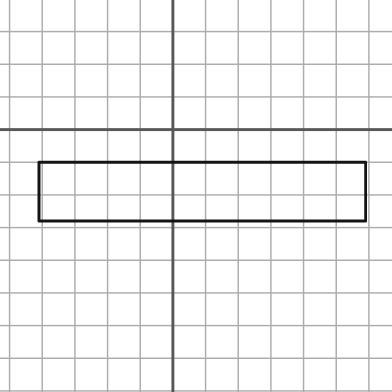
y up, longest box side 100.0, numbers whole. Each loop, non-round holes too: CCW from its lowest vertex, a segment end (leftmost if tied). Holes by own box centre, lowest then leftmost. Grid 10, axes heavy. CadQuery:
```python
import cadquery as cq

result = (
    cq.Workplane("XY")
    .moveTo(-41.0, -28.0)
    .lineTo(59.0, -28.0)
    .lineTo(59.0, -10.0)
    .lineTo(-41.0, -10.0)
    .close()
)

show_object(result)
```